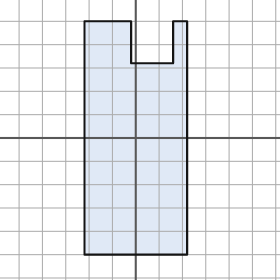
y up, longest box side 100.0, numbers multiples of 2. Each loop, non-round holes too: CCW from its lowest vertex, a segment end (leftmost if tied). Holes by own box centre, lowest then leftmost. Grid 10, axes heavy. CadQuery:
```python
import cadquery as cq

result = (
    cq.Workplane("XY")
    .moveTo(-22.0, -50.0)
    .lineTo(22.0, -50.0)
    .lineTo(22.0, 50.0)
    .lineTo(16.0, 50.0)
    .lineTo(16.0, 32.0)
    .lineTo(-2.0, 32.0)
    .lineTo(-2.0, 50.0)
    .lineTo(-22.0, 50.0)
    .close()
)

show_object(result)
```